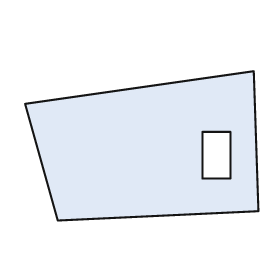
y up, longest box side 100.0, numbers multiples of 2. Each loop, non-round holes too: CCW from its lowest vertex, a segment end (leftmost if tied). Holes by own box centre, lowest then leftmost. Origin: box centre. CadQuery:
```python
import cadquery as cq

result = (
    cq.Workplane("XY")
    .moveTo(-36.0, -32.0)
    .lineTo(50.0, -28.0)
    .lineTo(48.0, 32.0)
    .lineTo(-50.0, 18.0)
    .close()
    .moveTo(26.0, -14.0)
    .lineTo(38.0, -14.0)
    .lineTo(38.0, 6.0)
    .lineTo(26.0, 6.0)
    .close()
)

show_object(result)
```